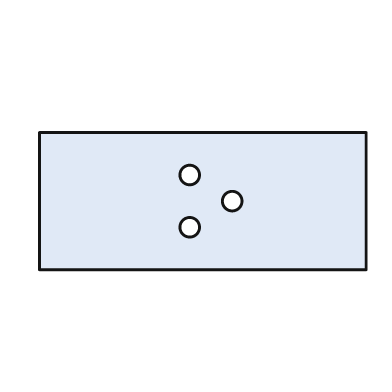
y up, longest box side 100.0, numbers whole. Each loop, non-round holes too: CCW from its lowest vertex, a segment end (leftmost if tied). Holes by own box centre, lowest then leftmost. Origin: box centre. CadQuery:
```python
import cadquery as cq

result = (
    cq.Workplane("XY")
    .moveTo(-50.0, -21.0)
    .lineTo(50.0, -21.0)
    .lineTo(50.0, 21.0)
    .lineTo(-50.0, 21.0)
    .close()
    .moveTo(-4.0, -8.0)
    .circle(3.0)
    .moveTo(9.0, 0.0)
    .circle(3.0)
    .moveTo(-4.0, 8.0)
    .circle(3.0)
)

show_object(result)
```